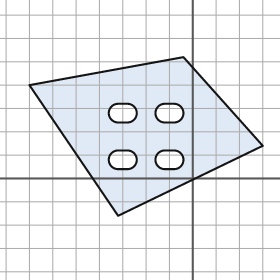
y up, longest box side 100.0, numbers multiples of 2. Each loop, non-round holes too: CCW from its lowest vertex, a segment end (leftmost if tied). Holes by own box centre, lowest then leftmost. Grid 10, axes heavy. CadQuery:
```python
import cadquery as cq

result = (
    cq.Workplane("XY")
    .moveTo(-32.0, -16.0)
    .lineTo(30.0, 14.0)
    .lineTo(-4.0, 52.0)
    .lineTo(-70.0, 40.0)
    .close()
    .moveTo(-32.0, 4.0)
    .lineTo(-28.0, 4.0)
    .threePointArc((-24.0, 8.0), (-28.0, 12.0))
    .lineTo(-32.0, 12.0)
    .threePointArc((-36.0, 8.0), (-32.0, 4.0))
    .close()
    .moveTo(-12.0, 4.0)
    .lineTo(-8.0, 4.0)
    .threePointArc((-4.0, 8.0), (-8.0, 12.0))
    .lineTo(-12.0, 12.0)
    .threePointArc((-16.0, 8.0), (-12.0, 4.0))
    .close()
    .moveTo(-32.0, 24.0)
    .lineTo(-28.0, 24.0)
    .threePointArc((-24.0, 28.0), (-28.0, 32.0))
    .lineTo(-32.0, 32.0)
    .threePointArc((-36.0, 28.0), (-32.0, 24.0))
    .close()
    .moveTo(-12.0, 24.0)
    .lineTo(-8.0, 24.0)
    .threePointArc((-4.0, 28.0), (-8.0, 32.0))
    .lineTo(-12.0, 32.0)
    .threePointArc((-16.0, 28.0), (-12.0, 24.0))
    .close()
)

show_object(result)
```